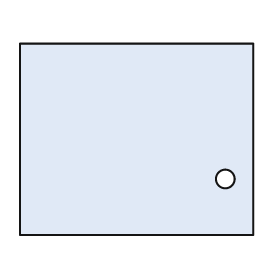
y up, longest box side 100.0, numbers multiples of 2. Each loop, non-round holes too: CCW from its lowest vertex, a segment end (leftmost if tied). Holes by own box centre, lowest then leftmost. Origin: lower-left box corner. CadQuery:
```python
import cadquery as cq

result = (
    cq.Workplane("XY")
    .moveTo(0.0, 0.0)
    .lineTo(100.0, 0.0)
    .lineTo(100.0, 82.0)
    .lineTo(0.0, 82.0)
    .close()
    .moveTo(88.0, 24.0)
    .circle(4.0)
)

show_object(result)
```